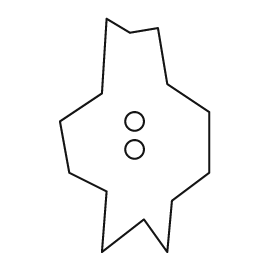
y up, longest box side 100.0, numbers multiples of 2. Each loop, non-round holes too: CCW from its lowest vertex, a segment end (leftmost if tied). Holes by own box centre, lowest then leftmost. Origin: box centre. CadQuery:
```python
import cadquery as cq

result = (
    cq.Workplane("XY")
    .moveTo(-14.0, -50.0)
    .lineTo(4.0, -36.0)
    .lineTo(14.0, -50.0)
    .lineTo(16.0, -28.0)
    .lineTo(32.0, -16.0)
    .lineTo(32.0, 10.0)
    .lineTo(14.0, 22.0)
    .lineTo(10.0, 46.0)
    .lineTo(-2.0, 44.0)
    .lineTo(-12.0, 50.0)
    .lineTo(-14.0, 18.0)
    .lineTo(-32.0, 6.0)
    .lineTo(-28.0, -16.0)
    .lineTo(-12.0, -24.0)
    .close()
    .moveTo(0.0, -6.0)
    .circle(4.0)
    .moveTo(0.0, 6.0)
    .circle(4.0)
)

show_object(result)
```